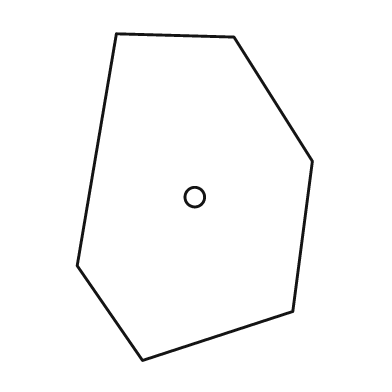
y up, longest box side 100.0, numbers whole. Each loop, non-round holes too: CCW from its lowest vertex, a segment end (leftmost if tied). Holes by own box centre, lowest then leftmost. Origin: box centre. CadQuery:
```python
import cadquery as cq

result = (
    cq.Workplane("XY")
    .moveTo(-16.0, -50.0)
    .lineTo(30.0, -35.0)
    .lineTo(36.0, 11.0)
    .lineTo(12.0, 49.0)
    .lineTo(-24.0, 50.0)
    .lineTo(-36.0, -21.0)
    .close()
    .moveTo(0.0, 0.0)
    .circle(3.0)
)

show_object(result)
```